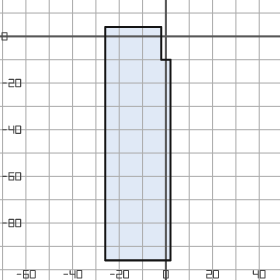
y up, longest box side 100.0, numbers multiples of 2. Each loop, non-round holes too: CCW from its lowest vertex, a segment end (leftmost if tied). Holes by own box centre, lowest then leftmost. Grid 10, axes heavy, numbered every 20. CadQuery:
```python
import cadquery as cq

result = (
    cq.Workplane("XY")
    .moveTo(-26.0, -96.0)
    .lineTo(2.0, -96.0)
    .lineTo(2.0, -10.0)
    .lineTo(-2.0, -10.0)
    .lineTo(-2.0, 4.0)
    .lineTo(-26.0, 4.0)
    .close()
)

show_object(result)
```